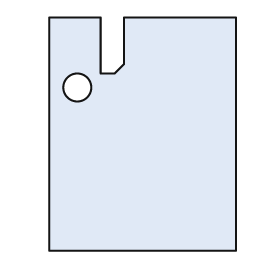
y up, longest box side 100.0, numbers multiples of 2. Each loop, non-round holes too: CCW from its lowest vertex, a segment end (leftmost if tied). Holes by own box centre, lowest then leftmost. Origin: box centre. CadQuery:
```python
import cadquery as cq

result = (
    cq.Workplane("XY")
    .moveTo(-40.0, -50.0)
    .lineTo(40.0, -50.0)
    .lineTo(40.0, 50.0)
    .lineTo(-8.0, 50.0)
    .lineTo(-8.0, 30.0)
    .lineTo(-12.0, 26.0)
    .lineTo(-18.0, 26.0)
    .lineTo(-18.0, 50.0)
    .lineTo(-40.0, 50.0)
    .close()
    .moveTo(-28.0, 20.0)
    .circle(6.0)
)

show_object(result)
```